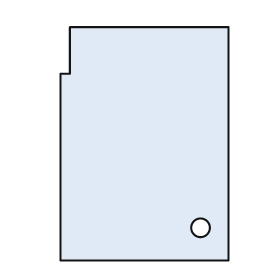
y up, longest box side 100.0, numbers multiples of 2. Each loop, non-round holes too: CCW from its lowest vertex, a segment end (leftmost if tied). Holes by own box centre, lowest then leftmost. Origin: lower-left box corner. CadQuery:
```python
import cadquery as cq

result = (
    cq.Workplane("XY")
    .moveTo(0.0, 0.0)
    .lineTo(72.0, 0.0)
    .lineTo(72.0, 100.0)
    .lineTo(4.0, 100.0)
    .lineTo(4.0, 80.0)
    .lineTo(0.0, 80.0)
    .close()
    .moveTo(60.0, 14.0)
    .circle(4.0)
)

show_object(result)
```